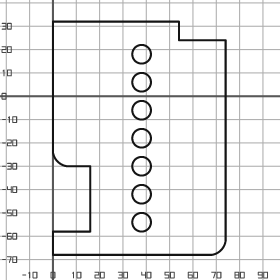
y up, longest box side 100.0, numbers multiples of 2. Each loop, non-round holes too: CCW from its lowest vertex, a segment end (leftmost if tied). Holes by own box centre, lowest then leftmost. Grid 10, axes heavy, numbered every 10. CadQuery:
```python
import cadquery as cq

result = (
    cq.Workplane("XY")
    .moveTo(0.0, -68.0)
    .lineTo(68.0, -68.0)
    .threePointArc((72.0, -66.0), (74.0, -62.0))
    .lineTo(74.0, 24.0)
    .lineTo(54.0, 24.0)
    .lineTo(54.0, 32.0)
    .lineTo(0.0, 32.0)
    .lineTo(0.0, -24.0)
    .threePointArc((2.0, -28.0), (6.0, -30.0))
    .lineTo(16.0, -30.0)
    .lineTo(16.0, -58.0)
    .lineTo(0.0, -58.0)
    .close()
    .moveTo(38.0, -54.0)
    .circle(4.0)
    .moveTo(38.0, -42.0)
    .circle(4.0)
    .moveTo(38.0, -30.0)
    .circle(4.0)
    .moveTo(38.0, -18.0)
    .circle(4.0)
    .moveTo(38.0, -6.0)
    .circle(4.0)
    .moveTo(38.0, 6.0)
    .circle(4.0)
    .moveTo(38.0, 18.0)
    .circle(4.0)
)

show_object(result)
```